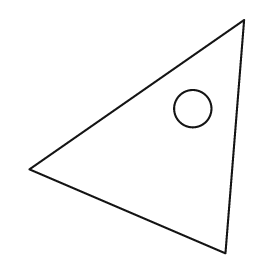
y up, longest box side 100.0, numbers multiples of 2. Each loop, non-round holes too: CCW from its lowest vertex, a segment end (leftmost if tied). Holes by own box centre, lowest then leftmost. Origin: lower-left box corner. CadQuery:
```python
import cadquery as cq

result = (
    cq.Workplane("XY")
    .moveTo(84.0, 0.0)
    .lineTo(92.0, 100.0)
    .lineTo(0.0, 36.0)
    .close()
    .moveTo(70.0, 62.0)
    .circle(8.0)
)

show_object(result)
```